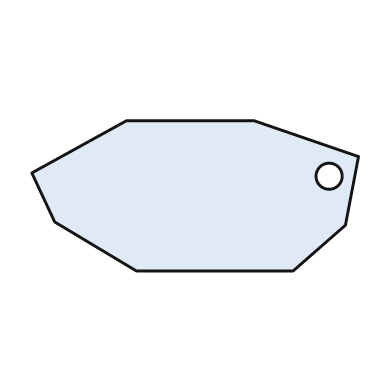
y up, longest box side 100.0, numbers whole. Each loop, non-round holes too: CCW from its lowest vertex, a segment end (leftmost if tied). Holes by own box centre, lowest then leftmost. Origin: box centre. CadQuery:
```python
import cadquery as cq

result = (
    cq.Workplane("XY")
    .moveTo(-18.0, -23.0)
    .lineTo(30.0, -23.0)
    .lineTo(46.0, -9.0)
    .lineTo(50.0, 12.0)
    .lineTo(18.0, 23.0)
    .lineTo(-21.0, 23.0)
    .lineTo(-50.0, 7.0)
    .lineTo(-43.0, -8.0)
    .close()
    .moveTo(41.0, 6.0)
    .circle(4.0)
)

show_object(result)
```